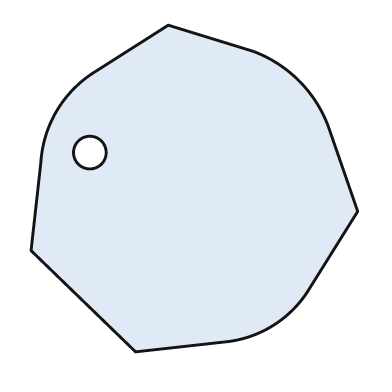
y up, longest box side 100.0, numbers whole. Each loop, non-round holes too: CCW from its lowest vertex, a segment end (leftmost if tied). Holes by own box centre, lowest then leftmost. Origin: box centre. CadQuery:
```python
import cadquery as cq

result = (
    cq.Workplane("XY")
    .moveTo(-18.0, -50.0)
    .lineTo(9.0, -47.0)
    .threePointArc((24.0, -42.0), (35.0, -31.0))
    .lineTo(50.0, -7.0)
    .lineTo(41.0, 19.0)
    .threePointArc((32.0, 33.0), (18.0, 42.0))
    .lineTo(-8.0, 50.0)
    .lineTo(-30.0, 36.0)
    .threePointArc((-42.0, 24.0), (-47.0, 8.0))
    .lineTo(-50.0, -19.0)
    .close()
    .moveTo(-32.0, 11.0)
    .circle(5.0)
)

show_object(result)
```